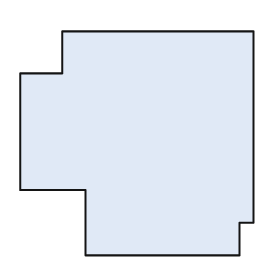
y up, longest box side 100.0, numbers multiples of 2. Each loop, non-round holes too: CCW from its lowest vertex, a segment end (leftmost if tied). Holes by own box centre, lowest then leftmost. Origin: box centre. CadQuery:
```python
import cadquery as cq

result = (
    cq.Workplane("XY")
    .moveTo(-22.0, -48.0)
    .lineTo(44.0, -48.0)
    .lineTo(44.0, -34.0)
    .lineTo(50.0, -34.0)
    .lineTo(50.0, 48.0)
    .lineTo(-32.0, 48.0)
    .lineTo(-32.0, 30.0)
    .lineTo(-50.0, 30.0)
    .lineTo(-50.0, -20.0)
    .lineTo(-22.0, -20.0)
    .close()
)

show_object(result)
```